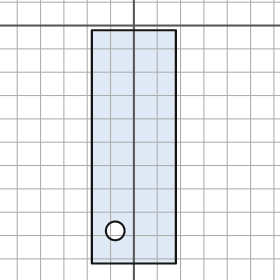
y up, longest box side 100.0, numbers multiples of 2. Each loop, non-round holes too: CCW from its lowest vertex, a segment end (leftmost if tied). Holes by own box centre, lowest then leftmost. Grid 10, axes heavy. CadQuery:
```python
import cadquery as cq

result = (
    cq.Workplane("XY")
    .moveTo(-18.0, -102.0)
    .lineTo(18.0, -102.0)
    .lineTo(18.0, -2.0)
    .lineTo(-18.0, -2.0)
    .close()
    .moveTo(-8.0, -88.0)
    .circle(4.0)
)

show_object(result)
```